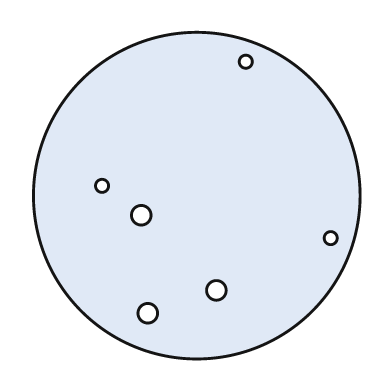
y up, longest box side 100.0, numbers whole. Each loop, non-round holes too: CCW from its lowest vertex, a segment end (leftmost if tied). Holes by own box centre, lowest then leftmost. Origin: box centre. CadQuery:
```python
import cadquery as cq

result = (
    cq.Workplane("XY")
    .moveTo(0.0, 0.0)
    .circle(50.0)
    .moveTo(-15.0, -36.0)
    .circle(3.0)
    .moveTo(6.0, -29.0)
    .circle(3.0)
    .moveTo(41.0, -13.0)
    .circle(2.0)
    .moveTo(-17.0, -6.0)
    .circle(3.0)
    .moveTo(-29.0, 3.0)
    .circle(2.0)
    .moveTo(15.0, 41.0)
    .circle(2.0)
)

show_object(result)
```